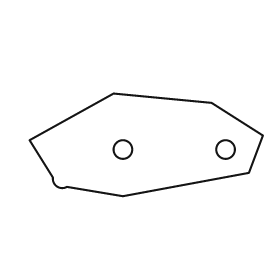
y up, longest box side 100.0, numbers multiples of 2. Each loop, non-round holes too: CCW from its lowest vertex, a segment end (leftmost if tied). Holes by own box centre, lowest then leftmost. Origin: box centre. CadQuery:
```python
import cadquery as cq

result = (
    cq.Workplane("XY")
    .moveTo(-10.0, -22.0)
    .lineTo(44.0, -12.0)
    .lineTo(50.0, 4.0)
    .lineTo(28.0, 18.0)
    .lineTo(-14.0, 22.0)
    .lineTo(-50.0, 2.0)
    .lineTo(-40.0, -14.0)
    .threePointArc((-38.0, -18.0), (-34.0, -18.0))
    .close()
    .moveTo(-10.0, -2.0)
    .circle(4.0)
    .moveTo(34.0, -2.0)
    .circle(4.0)
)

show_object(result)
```